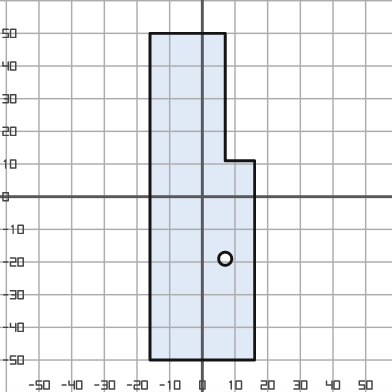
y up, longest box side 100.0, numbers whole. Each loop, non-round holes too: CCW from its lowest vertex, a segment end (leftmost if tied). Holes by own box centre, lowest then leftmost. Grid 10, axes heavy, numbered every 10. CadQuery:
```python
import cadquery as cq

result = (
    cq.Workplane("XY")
    .moveTo(-16.0, -50.0)
    .lineTo(16.0, -50.0)
    .lineTo(16.0, 11.0)
    .lineTo(7.0, 11.0)
    .lineTo(7.0, 50.0)
    .lineTo(-16.0, 50.0)
    .close()
    .moveTo(7.0, -19.0)
    .circle(2.0)
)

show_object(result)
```